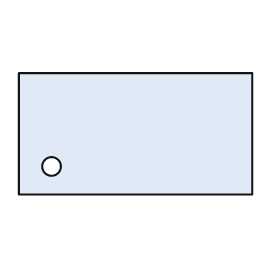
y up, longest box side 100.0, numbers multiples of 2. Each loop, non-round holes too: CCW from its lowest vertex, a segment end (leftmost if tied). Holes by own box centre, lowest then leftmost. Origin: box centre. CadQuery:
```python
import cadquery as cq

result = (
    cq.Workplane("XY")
    .moveTo(-50.0, -26.0)
    .lineTo(50.0, -26.0)
    .lineTo(50.0, 26.0)
    .lineTo(-50.0, 26.0)
    .close()
    .moveTo(-36.0, -14.0)
    .circle(4.0)
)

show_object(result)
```